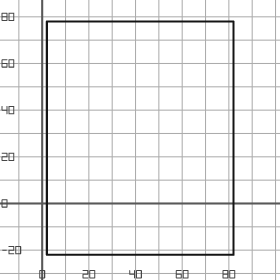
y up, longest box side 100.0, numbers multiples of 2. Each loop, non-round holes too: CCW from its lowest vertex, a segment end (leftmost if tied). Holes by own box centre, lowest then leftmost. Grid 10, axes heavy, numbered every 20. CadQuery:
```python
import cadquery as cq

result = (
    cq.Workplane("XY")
    .moveTo(2.0, -22.0)
    .lineTo(82.0, -22.0)
    .lineTo(82.0, 78.0)
    .lineTo(2.0, 78.0)
    .close()
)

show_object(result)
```